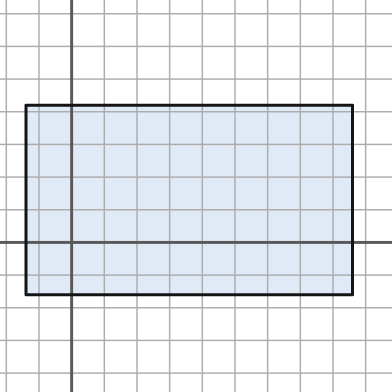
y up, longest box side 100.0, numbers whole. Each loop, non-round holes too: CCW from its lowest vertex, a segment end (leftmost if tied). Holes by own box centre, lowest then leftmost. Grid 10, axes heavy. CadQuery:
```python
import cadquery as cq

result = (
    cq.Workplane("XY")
    .moveTo(-14.0, -16.0)
    .lineTo(86.0, -16.0)
    .lineTo(86.0, 42.0)
    .lineTo(-14.0, 42.0)
    .close()
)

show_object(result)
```